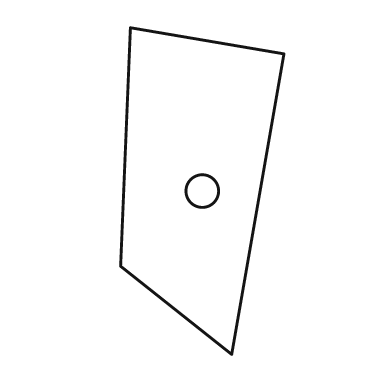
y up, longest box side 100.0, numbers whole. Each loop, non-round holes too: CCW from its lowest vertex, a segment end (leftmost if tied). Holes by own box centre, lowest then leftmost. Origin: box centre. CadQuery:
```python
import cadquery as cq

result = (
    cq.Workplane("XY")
    .moveTo(9.0, -50.0)
    .lineTo(25.0, 42.0)
    .lineTo(-22.0, 50.0)
    .lineTo(-25.0, -23.0)
    .close()
    .moveTo(0.0, 0.0)
    .circle(5.0)
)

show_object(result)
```